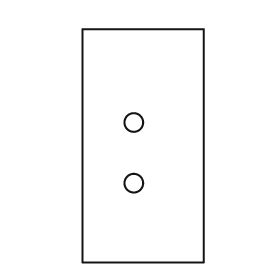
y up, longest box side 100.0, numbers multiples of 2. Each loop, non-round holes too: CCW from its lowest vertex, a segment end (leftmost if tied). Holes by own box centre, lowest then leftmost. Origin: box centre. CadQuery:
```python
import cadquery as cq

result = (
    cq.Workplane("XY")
    .moveTo(-26.0, -50.0)
    .lineTo(26.0, -50.0)
    .lineTo(26.0, 50.0)
    .lineTo(-26.0, 50.0)
    .close()
    .moveTo(-4.0, -16.0)
    .circle(4.0)
    .moveTo(-4.0, 10.0)
    .circle(4.0)
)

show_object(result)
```